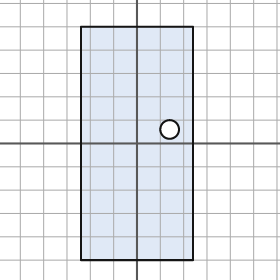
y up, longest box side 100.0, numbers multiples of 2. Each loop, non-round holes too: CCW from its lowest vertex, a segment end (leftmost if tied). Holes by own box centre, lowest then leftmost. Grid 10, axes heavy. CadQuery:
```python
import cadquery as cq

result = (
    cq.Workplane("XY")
    .moveTo(-24.0, -50.0)
    .lineTo(24.0, -50.0)
    .lineTo(24.0, 50.0)
    .lineTo(-24.0, 50.0)
    .close()
    .moveTo(14.0, 6.0)
    .circle(4.0)
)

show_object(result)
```